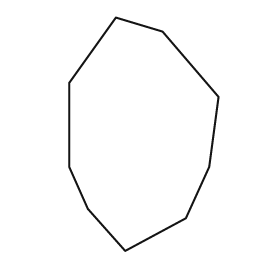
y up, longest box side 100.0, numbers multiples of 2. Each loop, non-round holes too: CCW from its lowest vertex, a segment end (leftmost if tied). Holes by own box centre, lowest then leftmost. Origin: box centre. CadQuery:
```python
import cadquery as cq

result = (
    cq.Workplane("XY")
    .moveTo(-8.0, -50.0)
    .lineTo(18.0, -36.0)
    .lineTo(28.0, -14.0)
    .lineTo(32.0, 16.0)
    .lineTo(8.0, 44.0)
    .lineTo(-12.0, 50.0)
    .lineTo(-32.0, 22.0)
    .lineTo(-32.0, -14.0)
    .lineTo(-24.0, -32.0)
    .close()
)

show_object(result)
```